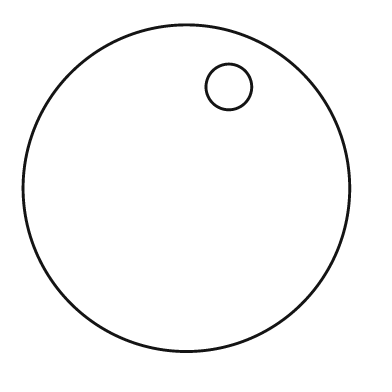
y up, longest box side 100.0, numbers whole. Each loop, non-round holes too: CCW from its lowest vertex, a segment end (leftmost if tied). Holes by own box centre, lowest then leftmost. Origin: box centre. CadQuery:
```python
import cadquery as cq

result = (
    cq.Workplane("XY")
    .moveTo(0.0, 0.0)
    .circle(50.0)
    .moveTo(13.0, 31.0)
    .circle(7.0)
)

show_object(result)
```